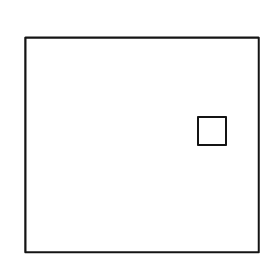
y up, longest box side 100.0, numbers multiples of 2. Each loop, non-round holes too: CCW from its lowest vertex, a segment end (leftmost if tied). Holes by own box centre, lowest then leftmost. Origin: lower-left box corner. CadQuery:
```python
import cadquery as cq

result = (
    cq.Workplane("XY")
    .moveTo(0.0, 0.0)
    .lineTo(100.0, 0.0)
    .lineTo(100.0, 92.0)
    .lineTo(0.0, 92.0)
    .close()
    .moveTo(74.0, 46.0)
    .lineTo(86.0, 46.0)
    .lineTo(86.0, 58.0)
    .lineTo(74.0, 58.0)
    .close()
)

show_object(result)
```